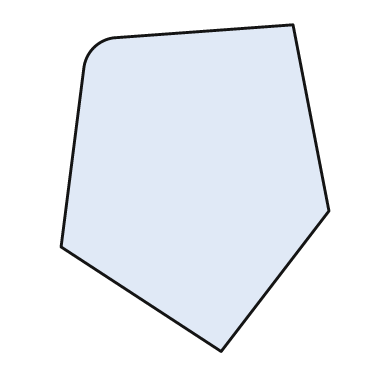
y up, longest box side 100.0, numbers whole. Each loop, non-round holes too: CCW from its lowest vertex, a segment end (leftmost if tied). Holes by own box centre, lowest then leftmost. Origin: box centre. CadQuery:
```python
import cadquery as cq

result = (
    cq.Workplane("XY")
    .moveTo(8.0, -50.0)
    .lineTo(41.0, -7.0)
    .lineTo(30.0, 50.0)
    .lineTo(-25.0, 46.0)
    .threePointArc((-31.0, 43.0), (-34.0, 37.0))
    .lineTo(-41.0, -18.0)
    .close()
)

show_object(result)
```